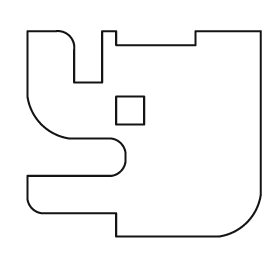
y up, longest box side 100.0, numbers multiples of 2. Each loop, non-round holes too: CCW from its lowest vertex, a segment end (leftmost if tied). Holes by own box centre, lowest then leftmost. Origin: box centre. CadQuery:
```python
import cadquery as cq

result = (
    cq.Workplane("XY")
    .moveTo(-12.0, -44.0)
    .lineTo(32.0, -44.0)
    .threePointArc((44.0, -38.0), (50.0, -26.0))
    .lineTo(50.0, 44.0)
    .lineTo(22.0, 44.0)
    .lineTo(22.0, 38.0)
    .lineTo(-12.0, 38.0)
    .lineTo(-12.0, 44.0)
    .lineTo(-18.0, 44.0)
    .lineTo(-18.0, 22.0)
    .lineTo(-30.0, 22.0)
    .lineTo(-30.0, 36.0)
    .threePointArc((-32.0, 42.0), (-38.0, 44.0))
    .lineTo(-50.0, 44.0)
    .lineTo(-50.0, 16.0)
    .threePointArc((-44.0, 4.0), (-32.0, -2.0))
    .lineTo(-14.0, -2.0)
    .threePointArc((-10.0, -4.0), (-8.0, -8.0))
    .lineTo(-8.0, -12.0)
    .threePointArc((-10.0, -16.0), (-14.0, -18.0))
    .lineTo(-50.0, -18.0)
    .lineTo(-50.0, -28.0)
    .threePointArc((-48.0, -32.0), (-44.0, -34.0))
    .lineTo(-12.0, -34.0)
    .close()
    .moveTo(-12.0, 4.0)
    .lineTo(0.0, 4.0)
    .lineTo(0.0, 16.0)
    .lineTo(-12.0, 16.0)
    .close()
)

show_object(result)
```